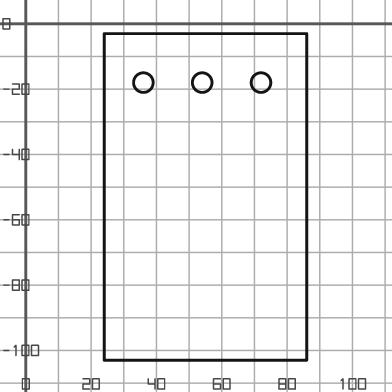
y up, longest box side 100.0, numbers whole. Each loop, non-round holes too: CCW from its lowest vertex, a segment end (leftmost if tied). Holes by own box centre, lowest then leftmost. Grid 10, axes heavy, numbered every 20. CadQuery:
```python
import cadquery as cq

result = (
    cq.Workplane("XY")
    .moveTo(24.0, -103.0)
    .lineTo(86.0, -103.0)
    .lineTo(86.0, -3.0)
    .lineTo(24.0, -3.0)
    .close()
    .moveTo(36.0, -18.0)
    .circle(3.0)
    .moveTo(54.0, -18.0)
    .circle(3.0)
    .moveTo(72.0, -18.0)
    .circle(3.0)
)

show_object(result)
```